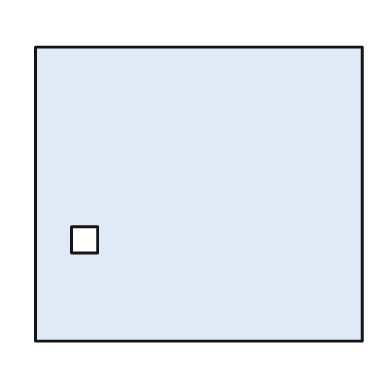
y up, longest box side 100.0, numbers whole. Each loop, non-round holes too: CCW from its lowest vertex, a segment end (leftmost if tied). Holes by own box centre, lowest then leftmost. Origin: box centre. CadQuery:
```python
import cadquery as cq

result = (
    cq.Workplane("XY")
    .moveTo(-50.0, -45.0)
    .lineTo(50.0, -45.0)
    .lineTo(50.0, 45.0)
    .lineTo(-50.0, 45.0)
    .close()
    .moveTo(-39.0, -18.0)
    .lineTo(-31.0, -18.0)
    .lineTo(-31.0, -10.0)
    .lineTo(-39.0, -10.0)
    .close()
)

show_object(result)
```